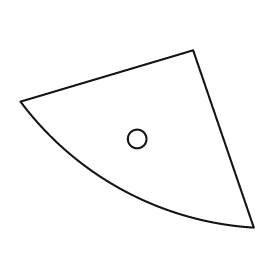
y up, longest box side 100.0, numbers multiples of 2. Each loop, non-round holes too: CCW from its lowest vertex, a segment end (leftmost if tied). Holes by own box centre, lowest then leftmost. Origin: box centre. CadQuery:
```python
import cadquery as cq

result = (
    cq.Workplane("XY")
    .moveTo(50.0, -38.0)
    .lineTo(24.0, 38.0)
    .lineTo(-50.0, 16.0)
    .threePointArc((-6.0, -22.0), (50.0, -38.0))
    .close()
    .moveTo(0.0, 0.0)
    .circle(4.0)
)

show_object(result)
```